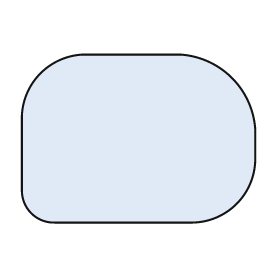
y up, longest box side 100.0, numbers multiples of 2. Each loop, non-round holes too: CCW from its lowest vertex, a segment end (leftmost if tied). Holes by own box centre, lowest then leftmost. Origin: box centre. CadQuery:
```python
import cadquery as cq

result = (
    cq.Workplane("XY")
    .moveTo(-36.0, -36.0)
    .lineTo(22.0, -36.0)
    .threePointArc((42.0, -28.0), (50.0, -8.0))
    .lineTo(50.0, 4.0)
    .threePointArc((40.0, 26.0), (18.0, 36.0))
    .lineTo(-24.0, 36.0)
    .threePointArc((-42.0, 28.0), (-50.0, 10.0))
    .lineTo(-50.0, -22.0)
    .threePointArc((-46.0, -32.0), (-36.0, -36.0))
    .close()
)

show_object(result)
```